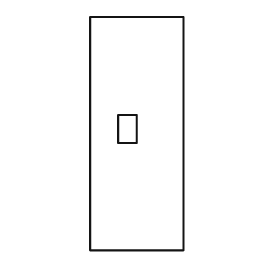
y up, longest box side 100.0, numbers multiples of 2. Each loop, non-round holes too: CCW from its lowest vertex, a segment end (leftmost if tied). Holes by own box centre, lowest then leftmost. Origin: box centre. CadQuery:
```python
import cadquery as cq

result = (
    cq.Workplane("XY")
    .moveTo(-20.0, -50.0)
    .lineTo(20.0, -50.0)
    .lineTo(20.0, 50.0)
    .lineTo(-20.0, 50.0)
    .close()
    .moveTo(-8.0, -4.0)
    .lineTo(0.0, -4.0)
    .lineTo(0.0, 8.0)
    .lineTo(-8.0, 8.0)
    .close()
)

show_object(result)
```